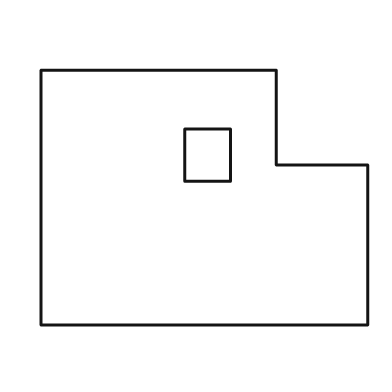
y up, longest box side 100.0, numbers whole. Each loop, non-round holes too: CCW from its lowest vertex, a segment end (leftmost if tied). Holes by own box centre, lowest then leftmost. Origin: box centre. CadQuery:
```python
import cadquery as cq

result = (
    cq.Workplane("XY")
    .moveTo(-50.0, -39.0)
    .lineTo(50.0, -39.0)
    .lineTo(50.0, 10.0)
    .lineTo(22.0, 10.0)
    .lineTo(22.0, 39.0)
    .lineTo(-50.0, 39.0)
    .close()
    .moveTo(-6.0, 5.0)
    .lineTo(8.0, 5.0)
    .lineTo(8.0, 21.0)
    .lineTo(-6.0, 21.0)
    .close()
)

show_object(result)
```